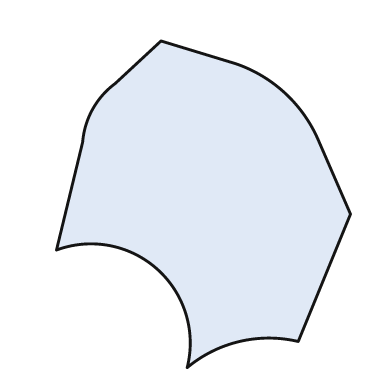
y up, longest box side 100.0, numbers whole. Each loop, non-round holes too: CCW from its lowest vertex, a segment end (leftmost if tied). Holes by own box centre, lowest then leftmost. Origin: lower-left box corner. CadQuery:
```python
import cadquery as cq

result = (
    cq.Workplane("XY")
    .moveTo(40.0, 0.0)
    .threePointArc((56.0, 8.0), (74.0, 8.0))
    .lineTo(90.0, 47.0)
    .lineTo(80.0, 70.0)
    .threePointArc((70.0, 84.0), (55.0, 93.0))
    .lineTo(32.0, 100.0)
    .lineTo(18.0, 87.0)
    .threePointArc((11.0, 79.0), (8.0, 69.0))
    .lineTo(0.0, 36.0)
    .threePointArc((31.0, 30.0), (40.0, 0.0))
    .close()
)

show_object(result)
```